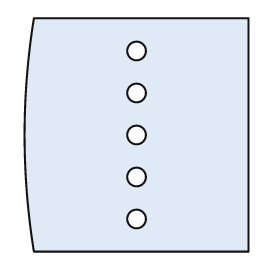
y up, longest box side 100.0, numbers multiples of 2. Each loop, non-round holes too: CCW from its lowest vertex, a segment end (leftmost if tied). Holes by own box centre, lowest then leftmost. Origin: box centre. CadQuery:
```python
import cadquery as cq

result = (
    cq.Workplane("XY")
    .moveTo(-44.0, -50.0)
    .lineTo(48.0, -50.0)
    .lineTo(48.0, 50.0)
    .lineTo(-44.0, 50.0)
    .threePointArc((-48.0, 0.0), (-44.0, -50.0))
    .close()
    .moveTo(0.0, -36.0)
    .circle(4.0)
    .moveTo(0.0, -18.0)
    .circle(4.0)
    .moveTo(0.0, 0.0)
    .circle(4.0)
    .moveTo(0.0, 18.0)
    .circle(4.0)
    .moveTo(0.0, 36.0)
    .circle(4.0)
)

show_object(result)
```